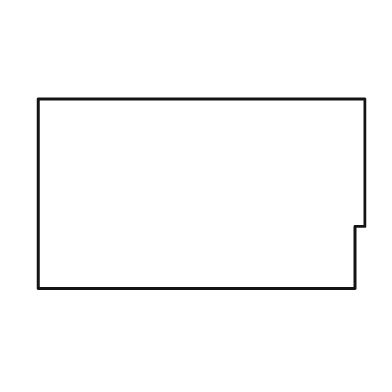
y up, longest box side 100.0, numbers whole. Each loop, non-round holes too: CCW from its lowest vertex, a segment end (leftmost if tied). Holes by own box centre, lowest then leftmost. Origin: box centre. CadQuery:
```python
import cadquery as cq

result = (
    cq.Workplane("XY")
    .moveTo(-50.0, -29.0)
    .lineTo(47.0, -29.0)
    .lineTo(47.0, -10.0)
    .lineTo(50.0, -10.0)
    .lineTo(50.0, 29.0)
    .lineTo(-50.0, 29.0)
    .close()
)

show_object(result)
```